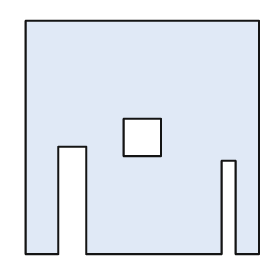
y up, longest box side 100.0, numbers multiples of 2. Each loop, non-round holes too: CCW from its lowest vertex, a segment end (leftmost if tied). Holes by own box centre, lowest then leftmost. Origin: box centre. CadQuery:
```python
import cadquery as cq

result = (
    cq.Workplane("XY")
    .moveTo(-50.0, -50.0)
    .lineTo(-36.0, -50.0)
    .lineTo(-36.0, -4.0)
    .lineTo(-24.0, -4.0)
    .lineTo(-24.0, -50.0)
    .lineTo(34.0, -50.0)
    .lineTo(34.0, -10.0)
    .lineTo(40.0, -10.0)
    .lineTo(40.0, -50.0)
    .lineTo(50.0, -50.0)
    .lineTo(50.0, 50.0)
    .lineTo(-50.0, 50.0)
    .close()
    .moveTo(-8.0, -8.0)
    .lineTo(8.0, -8.0)
    .lineTo(8.0, 8.0)
    .lineTo(-8.0, 8.0)
    .close()
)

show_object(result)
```